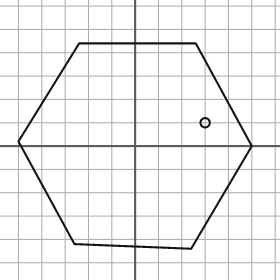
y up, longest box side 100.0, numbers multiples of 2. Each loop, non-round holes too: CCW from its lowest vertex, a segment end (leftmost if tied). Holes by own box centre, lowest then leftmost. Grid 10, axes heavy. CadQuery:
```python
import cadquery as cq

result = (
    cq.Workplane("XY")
    .moveTo(24.0, -44.0)
    .lineTo(50.0, 0.0)
    .lineTo(26.0, 44.0)
    .lineTo(-24.0, 44.0)
    .lineTo(-50.0, 2.0)
    .lineTo(-26.0, -42.0)
    .close()
    .moveTo(30.0, 10.0)
    .circle(2.0)
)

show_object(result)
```